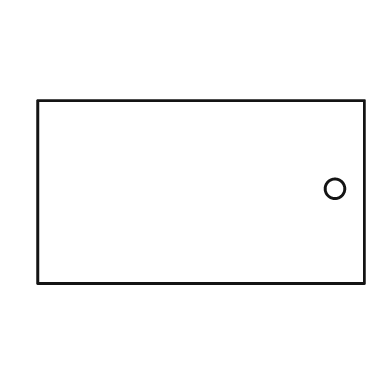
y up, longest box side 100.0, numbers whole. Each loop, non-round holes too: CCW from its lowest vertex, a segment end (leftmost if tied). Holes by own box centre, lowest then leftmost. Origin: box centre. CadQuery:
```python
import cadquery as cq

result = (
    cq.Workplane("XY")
    .moveTo(-50.0, -28.0)
    .lineTo(50.0, -28.0)
    .lineTo(50.0, 28.0)
    .lineTo(-50.0, 28.0)
    .close()
    .moveTo(41.0, 1.0)
    .circle(3.0)
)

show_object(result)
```